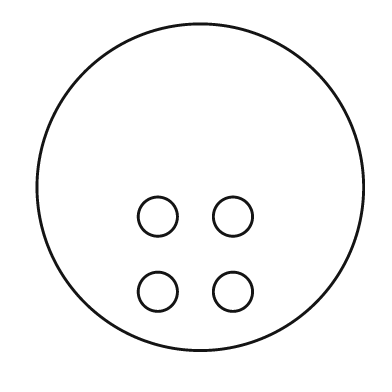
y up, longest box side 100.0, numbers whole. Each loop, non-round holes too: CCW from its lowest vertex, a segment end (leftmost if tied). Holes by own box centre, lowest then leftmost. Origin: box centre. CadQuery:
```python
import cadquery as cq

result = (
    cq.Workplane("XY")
    .moveTo(0.0, 0.0)
    .circle(50.0)
    .moveTo(-13.0, -32.0)
    .circle(6.0)
    .moveTo(10.0, -32.0)
    .circle(6.0)
    .moveTo(-13.0, -9.0)
    .circle(6.0)
    .moveTo(10.0, -9.0)
    .circle(6.0)
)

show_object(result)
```